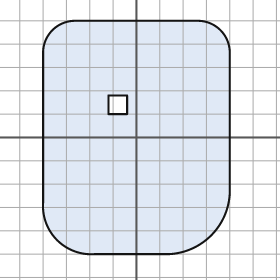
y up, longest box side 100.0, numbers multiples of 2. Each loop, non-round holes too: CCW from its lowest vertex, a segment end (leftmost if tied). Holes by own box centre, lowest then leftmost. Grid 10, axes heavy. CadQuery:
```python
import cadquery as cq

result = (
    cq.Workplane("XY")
    .moveTo(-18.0, -50.0)
    .lineTo(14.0, -50.0)
    .threePointArc((32.0, -42.0), (40.0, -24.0))
    .lineTo(40.0, 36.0)
    .threePointArc((36.0, 46.0), (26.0, 50.0))
    .lineTo(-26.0, 50.0)
    .threePointArc((-36.0, 46.0), (-40.0, 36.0))
    .lineTo(-40.0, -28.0)
    .threePointArc((-34.0, -44.0), (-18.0, -50.0))
    .close()
    .moveTo(-12.0, 10.0)
    .lineTo(-4.0, 10.0)
    .lineTo(-4.0, 18.0)
    .lineTo(-12.0, 18.0)
    .close()
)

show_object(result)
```